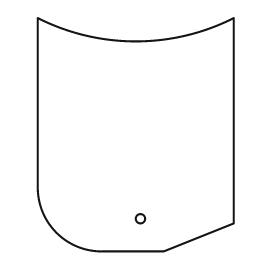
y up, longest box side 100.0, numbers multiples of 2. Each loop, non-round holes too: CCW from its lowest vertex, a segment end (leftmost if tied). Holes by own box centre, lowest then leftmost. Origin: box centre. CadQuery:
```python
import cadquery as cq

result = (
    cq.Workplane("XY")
    .moveTo(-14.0, -50.0)
    .lineTo(12.0, -50.0)
    .lineTo(42.0, -38.0)
    .lineTo(42.0, 50.0)
    .threePointArc((0.0, 40.0), (-42.0, 50.0))
    .lineTo(-42.0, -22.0)
    .threePointArc((-34.0, -42.0), (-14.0, -50.0))
    .close()
    .moveTo(2.0, -36.0)
    .circle(2.0)
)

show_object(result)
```